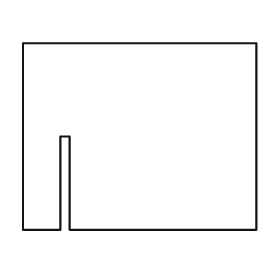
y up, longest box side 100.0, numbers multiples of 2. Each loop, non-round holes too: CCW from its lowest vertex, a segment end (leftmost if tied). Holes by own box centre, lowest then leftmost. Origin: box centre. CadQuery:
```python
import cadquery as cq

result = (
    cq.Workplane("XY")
    .moveTo(-50.0, -40.0)
    .lineTo(-34.0, -40.0)
    .lineTo(-34.0, 0.0)
    .lineTo(-30.0, 0.0)
    .lineTo(-30.0, -40.0)
    .lineTo(50.0, -40.0)
    .lineTo(50.0, 40.0)
    .lineTo(-50.0, 40.0)
    .close()
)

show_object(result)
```